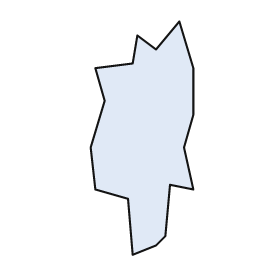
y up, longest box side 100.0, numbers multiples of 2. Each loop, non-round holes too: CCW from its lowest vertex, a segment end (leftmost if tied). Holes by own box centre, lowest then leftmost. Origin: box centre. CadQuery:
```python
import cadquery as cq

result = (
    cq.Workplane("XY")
    .moveTo(-4.0, -50.0)
    .lineTo(6.0, -46.0)
    .lineTo(10.0, -42.0)
    .lineTo(12.0, -20.0)
    .lineTo(22.0, -22.0)
    .lineTo(18.0, -4.0)
    .lineTo(22.0, 10.0)
    .lineTo(22.0, 30.0)
    .lineTo(16.0, 50.0)
    .lineTo(6.0, 38.0)
    .lineTo(-2.0, 44.0)
    .lineTo(-4.0, 32.0)
    .lineTo(-20.0, 30.0)
    .lineTo(-16.0, 16.0)
    .lineTo(-22.0, -4.0)
    .lineTo(-20.0, -22.0)
    .lineTo(-6.0, -26.0)
    .close()
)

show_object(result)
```